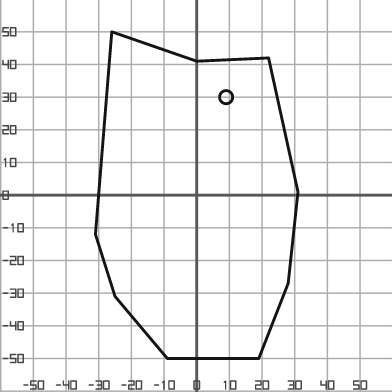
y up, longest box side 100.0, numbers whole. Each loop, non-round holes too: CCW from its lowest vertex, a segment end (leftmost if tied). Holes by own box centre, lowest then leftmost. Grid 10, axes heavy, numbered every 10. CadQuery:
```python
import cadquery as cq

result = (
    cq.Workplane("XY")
    .moveTo(-9.0, -50.0)
    .lineTo(19.0, -50.0)
    .lineTo(28.0, -27.0)
    .lineTo(31.0, 1.0)
    .lineTo(22.0, 42.0)
    .lineTo(0.0, 41.0)
    .lineTo(-26.0, 50.0)
    .lineTo(-31.0, -12.0)
    .lineTo(-25.0, -31.0)
    .close()
    .moveTo(9.0, 30.0)
    .circle(2.0)
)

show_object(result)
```